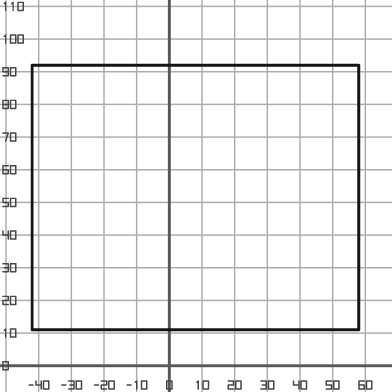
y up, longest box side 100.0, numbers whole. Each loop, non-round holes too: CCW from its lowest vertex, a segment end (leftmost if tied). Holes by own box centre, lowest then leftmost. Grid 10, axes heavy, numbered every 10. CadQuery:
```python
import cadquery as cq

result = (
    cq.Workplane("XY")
    .moveTo(-42.0, 11.0)
    .lineTo(58.0, 11.0)
    .lineTo(58.0, 92.0)
    .lineTo(-42.0, 92.0)
    .close()
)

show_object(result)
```